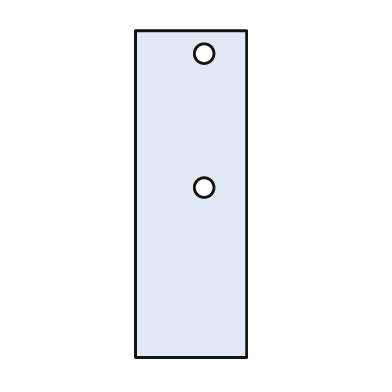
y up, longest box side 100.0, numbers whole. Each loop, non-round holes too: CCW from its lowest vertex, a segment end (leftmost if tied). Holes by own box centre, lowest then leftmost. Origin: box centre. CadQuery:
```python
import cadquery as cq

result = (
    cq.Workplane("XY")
    .moveTo(-17.0, -50.0)
    .lineTo(17.0, -50.0)
    .lineTo(17.0, 50.0)
    .lineTo(-17.0, 50.0)
    .close()
    .moveTo(4.0, 2.0)
    .circle(3.0)
    .moveTo(4.0, 43.0)
    .circle(3.0)
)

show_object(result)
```